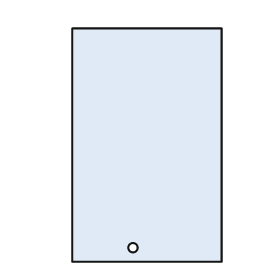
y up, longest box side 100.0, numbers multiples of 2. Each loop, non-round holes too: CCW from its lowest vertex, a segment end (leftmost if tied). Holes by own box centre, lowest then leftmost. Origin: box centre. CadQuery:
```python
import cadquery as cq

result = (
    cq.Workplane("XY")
    .moveTo(-32.0, -50.0)
    .lineTo(32.0, -50.0)
    .lineTo(32.0, 50.0)
    .lineTo(-32.0, 50.0)
    .close()
    .moveTo(-6.0, -44.0)
    .circle(2.0)
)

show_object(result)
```